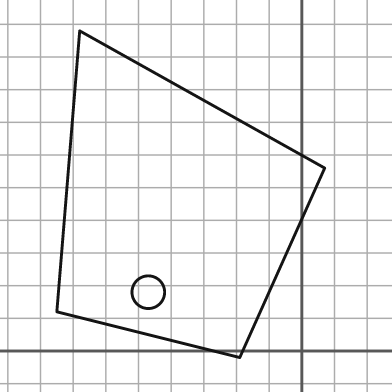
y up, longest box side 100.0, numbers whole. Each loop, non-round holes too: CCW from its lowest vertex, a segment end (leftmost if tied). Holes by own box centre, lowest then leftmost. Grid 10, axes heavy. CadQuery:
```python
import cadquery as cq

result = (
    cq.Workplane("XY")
    .moveTo(-19.0, -2.0)
    .lineTo(7.0, 56.0)
    .lineTo(-68.0, 98.0)
    .lineTo(-75.0, 12.0)
    .close()
    .moveTo(-47.0, 18.0)
    .circle(5.0)
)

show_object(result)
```